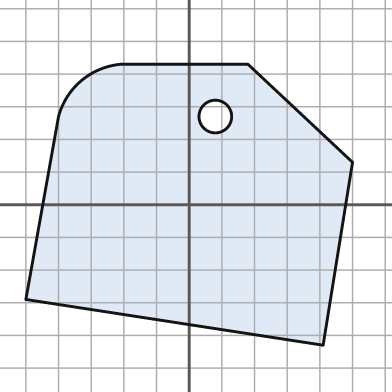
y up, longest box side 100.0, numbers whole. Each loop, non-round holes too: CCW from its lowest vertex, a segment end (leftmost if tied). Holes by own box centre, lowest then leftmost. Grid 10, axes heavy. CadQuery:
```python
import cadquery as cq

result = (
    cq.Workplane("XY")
    .moveTo(41.0, -43.0)
    .lineTo(50.0, 13.0)
    .lineTo(18.0, 43.0)
    .lineTo(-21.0, 43.0)
    .threePointArc((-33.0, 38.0), (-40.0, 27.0))
    .lineTo(-50.0, -29.0)
    .close()
    .moveTo(8.0, 27.0)
    .circle(5.0)
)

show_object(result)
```